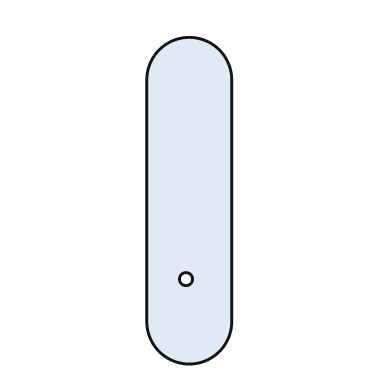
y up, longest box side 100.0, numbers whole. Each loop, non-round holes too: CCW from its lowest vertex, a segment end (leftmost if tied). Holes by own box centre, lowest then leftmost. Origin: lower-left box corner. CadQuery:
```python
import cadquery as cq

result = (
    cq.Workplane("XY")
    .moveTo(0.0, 13.0)
    .threePointArc((13.0, 0.0), (26.0, 13.0))
    .lineTo(26.0, 87.0)
    .threePointArc((13.0, 100.0), (0.0, 87.0))
    .close()
    .moveTo(12.0, 26.0)
    .circle(2.0)
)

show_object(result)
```